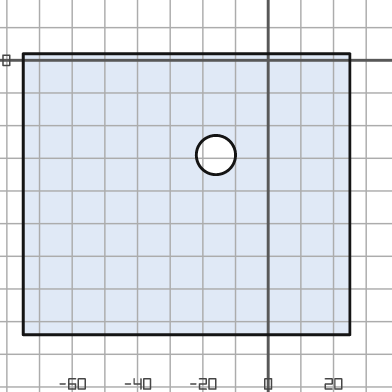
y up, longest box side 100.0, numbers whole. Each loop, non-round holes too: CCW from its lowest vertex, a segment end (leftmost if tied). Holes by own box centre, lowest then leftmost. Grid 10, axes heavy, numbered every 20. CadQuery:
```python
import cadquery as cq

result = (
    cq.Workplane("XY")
    .moveTo(-75.0, -84.0)
    .lineTo(25.0, -84.0)
    .lineTo(25.0, 2.0)
    .lineTo(-75.0, 2.0)
    .close()
    .moveTo(-16.0, -29.0)
    .circle(6.0)
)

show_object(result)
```